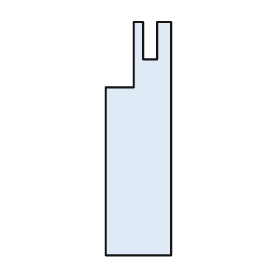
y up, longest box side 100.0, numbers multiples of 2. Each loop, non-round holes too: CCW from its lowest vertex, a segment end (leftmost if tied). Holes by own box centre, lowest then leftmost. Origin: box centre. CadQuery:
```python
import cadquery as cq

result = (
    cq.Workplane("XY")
    .moveTo(-14.0, -50.0)
    .lineTo(14.0, -50.0)
    .lineTo(14.0, 50.0)
    .lineTo(8.0, 50.0)
    .lineTo(8.0, 34.0)
    .lineTo(2.0, 34.0)
    .lineTo(2.0, 50.0)
    .lineTo(-2.0, 50.0)
    .lineTo(-2.0, 22.0)
    .lineTo(-14.0, 22.0)
    .close()
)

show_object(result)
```